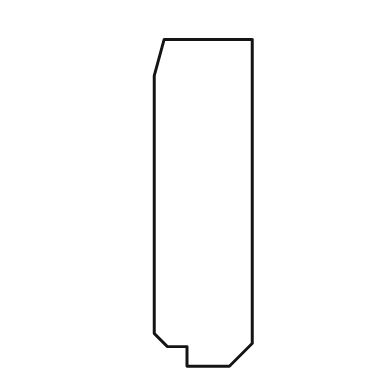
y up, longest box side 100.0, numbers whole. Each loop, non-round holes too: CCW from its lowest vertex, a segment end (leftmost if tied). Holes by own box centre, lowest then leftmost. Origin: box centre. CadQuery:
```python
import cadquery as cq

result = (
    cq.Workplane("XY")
    .moveTo(-5.0, -50.0)
    .lineTo(8.0, -50.0)
    .lineTo(15.0, -43.0)
    .lineTo(15.0, 50.0)
    .lineTo(-12.0, 50.0)
    .lineTo(-15.0, 39.0)
    .lineTo(-15.0, -40.0)
    .lineTo(-11.0, -44.0)
    .lineTo(-5.0, -44.0)
    .close()
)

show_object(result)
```